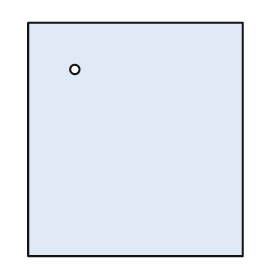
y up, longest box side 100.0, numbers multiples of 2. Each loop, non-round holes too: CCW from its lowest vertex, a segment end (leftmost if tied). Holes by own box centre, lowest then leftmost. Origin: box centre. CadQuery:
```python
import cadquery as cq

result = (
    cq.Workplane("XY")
    .moveTo(-46.0, -50.0)
    .lineTo(46.0, -50.0)
    .lineTo(46.0, 50.0)
    .lineTo(-46.0, 50.0)
    .close()
    .moveTo(-26.0, 30.0)
    .circle(2.0)
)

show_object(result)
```